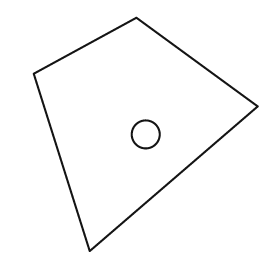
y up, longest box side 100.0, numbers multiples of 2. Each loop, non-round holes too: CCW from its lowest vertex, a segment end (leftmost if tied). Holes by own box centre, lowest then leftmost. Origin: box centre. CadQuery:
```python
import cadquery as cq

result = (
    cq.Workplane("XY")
    .moveTo(-24.0, -50.0)
    .lineTo(48.0, 12.0)
    .lineTo(-4.0, 50.0)
    .lineTo(-48.0, 26.0)
    .close()
    .moveTo(0.0, 0.0)
    .circle(6.0)
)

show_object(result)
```